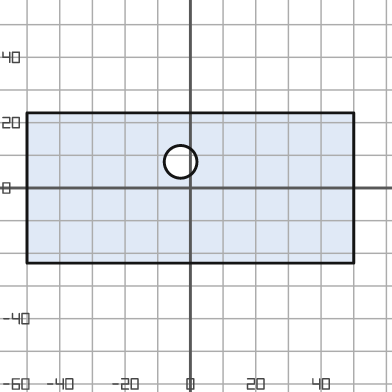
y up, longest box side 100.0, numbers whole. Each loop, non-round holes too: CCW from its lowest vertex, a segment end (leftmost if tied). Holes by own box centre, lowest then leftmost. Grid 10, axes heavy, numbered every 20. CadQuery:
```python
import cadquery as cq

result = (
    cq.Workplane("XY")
    .moveTo(-50.0, -23.0)
    .lineTo(50.0, -23.0)
    .lineTo(50.0, 23.0)
    .lineTo(-50.0, 23.0)
    .close()
    .moveTo(-3.0, 8.0)
    .circle(5.0)
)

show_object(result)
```